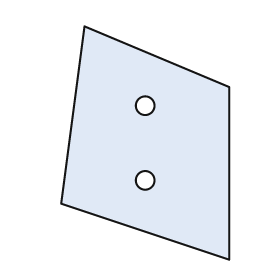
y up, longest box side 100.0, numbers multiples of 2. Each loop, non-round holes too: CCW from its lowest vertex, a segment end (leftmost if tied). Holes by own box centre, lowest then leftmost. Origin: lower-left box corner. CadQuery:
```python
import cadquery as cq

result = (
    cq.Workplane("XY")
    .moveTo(72.0, 0.0)
    .lineTo(72.0, 74.0)
    .lineTo(10.0, 100.0)
    .lineTo(0.0, 24.0)
    .close()
    .moveTo(36.0, 34.0)
    .circle(4.0)
    .moveTo(36.0, 66.0)
    .circle(4.0)
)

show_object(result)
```